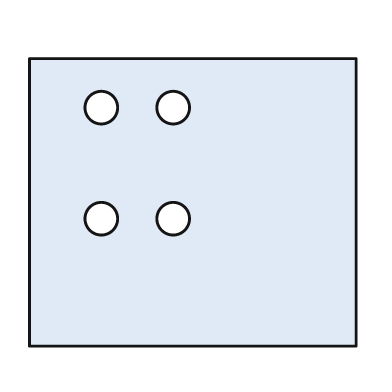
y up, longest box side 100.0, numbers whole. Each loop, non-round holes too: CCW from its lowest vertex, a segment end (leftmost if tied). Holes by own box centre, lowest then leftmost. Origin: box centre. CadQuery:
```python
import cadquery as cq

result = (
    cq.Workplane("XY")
    .moveTo(-50.0, -44.0)
    .lineTo(50.0, -44.0)
    .lineTo(50.0, 44.0)
    .lineTo(-50.0, 44.0)
    .close()
    .moveTo(-28.0, -5.0)
    .circle(5.0)
    .moveTo(-6.0, -5.0)
    .circle(5.0)
    .moveTo(-28.0, 29.0)
    .circle(5.0)
    .moveTo(-6.0, 29.0)
    .circle(5.0)
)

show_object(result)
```